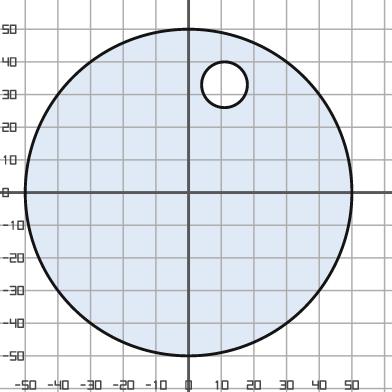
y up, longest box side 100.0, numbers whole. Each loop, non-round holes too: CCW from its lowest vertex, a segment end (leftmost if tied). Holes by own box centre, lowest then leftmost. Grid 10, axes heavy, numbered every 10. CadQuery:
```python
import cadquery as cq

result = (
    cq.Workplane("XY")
    .moveTo(0.0, 0.0)
    .circle(50.0)
    .moveTo(11.0, 33.0)
    .circle(7.0)
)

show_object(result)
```